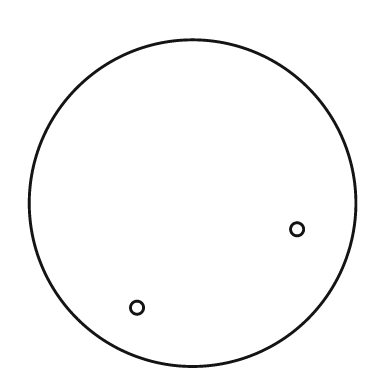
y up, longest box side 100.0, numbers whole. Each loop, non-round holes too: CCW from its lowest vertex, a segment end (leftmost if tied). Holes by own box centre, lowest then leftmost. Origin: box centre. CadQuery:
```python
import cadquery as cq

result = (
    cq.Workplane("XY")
    .moveTo(0.0, 0.0)
    .circle(50.0)
    .moveTo(-17.0, -32.0)
    .circle(2.0)
    .moveTo(32.0, -8.0)
    .circle(2.0)
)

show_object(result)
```